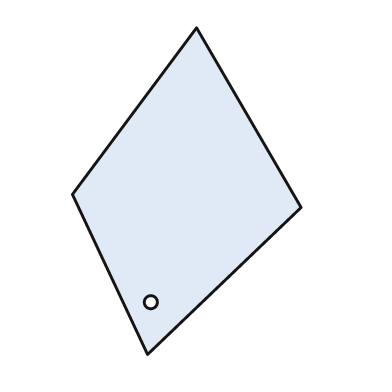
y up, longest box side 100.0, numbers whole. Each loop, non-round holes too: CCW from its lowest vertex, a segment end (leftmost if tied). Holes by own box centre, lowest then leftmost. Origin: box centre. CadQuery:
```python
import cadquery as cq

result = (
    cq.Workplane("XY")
    .moveTo(-12.0, -50.0)
    .lineTo(35.0, -5.0)
    .lineTo(3.0, 50.0)
    .lineTo(-35.0, -1.0)
    .close()
    .moveTo(-11.0, -34.0)
    .circle(2.0)
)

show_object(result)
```